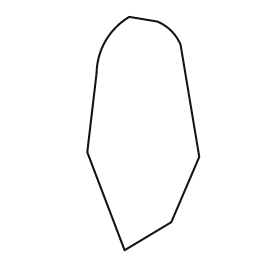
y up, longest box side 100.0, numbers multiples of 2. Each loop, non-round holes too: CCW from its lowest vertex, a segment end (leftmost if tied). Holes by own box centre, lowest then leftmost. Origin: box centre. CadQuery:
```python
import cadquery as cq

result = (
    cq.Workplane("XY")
    .moveTo(-8.0, -50.0)
    .lineTo(12.0, -38.0)
    .lineTo(24.0, -10.0)
    .lineTo(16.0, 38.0)
    .threePointArc((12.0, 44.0), (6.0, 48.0))
    .lineTo(-6.0, 50.0)
    .threePointArc((-16.0, 40.0), (-20.0, 26.0))
    .lineTo(-24.0, -8.0)
    .close()
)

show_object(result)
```